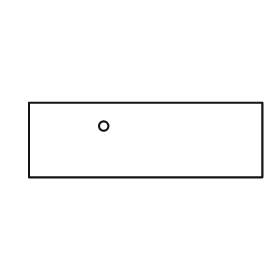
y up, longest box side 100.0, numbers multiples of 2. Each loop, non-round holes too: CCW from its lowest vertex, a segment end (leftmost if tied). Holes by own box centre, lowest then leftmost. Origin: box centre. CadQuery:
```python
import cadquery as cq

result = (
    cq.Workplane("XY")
    .moveTo(-50.0, -16.0)
    .lineTo(50.0, -16.0)
    .lineTo(50.0, 16.0)
    .lineTo(-50.0, 16.0)
    .close()
    .moveTo(-18.0, 6.0)
    .circle(2.0)
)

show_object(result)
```